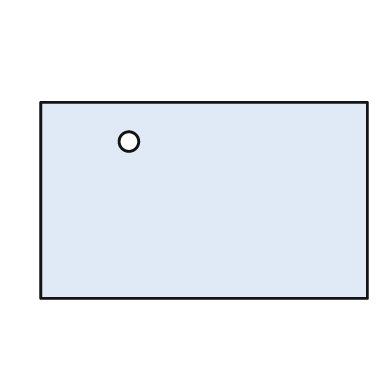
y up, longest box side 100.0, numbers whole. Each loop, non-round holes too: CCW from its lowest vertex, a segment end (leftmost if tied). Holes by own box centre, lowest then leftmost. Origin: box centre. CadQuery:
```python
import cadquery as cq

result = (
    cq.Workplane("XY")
    .moveTo(-50.0, -30.0)
    .lineTo(50.0, -30.0)
    .lineTo(50.0, 30.0)
    .lineTo(-50.0, 30.0)
    .close()
    .moveTo(-23.0, 18.0)
    .circle(3.0)
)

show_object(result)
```